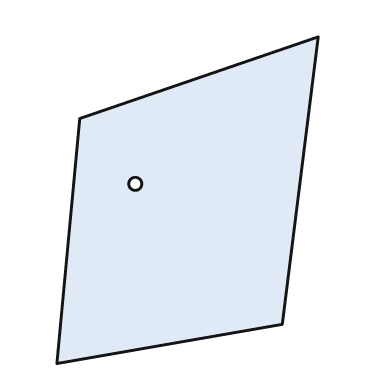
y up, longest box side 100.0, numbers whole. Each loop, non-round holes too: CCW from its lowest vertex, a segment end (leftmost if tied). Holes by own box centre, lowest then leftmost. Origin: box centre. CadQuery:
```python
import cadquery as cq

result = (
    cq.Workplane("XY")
    .moveTo(-40.0, -50.0)
    .lineTo(29.0, -38.0)
    .lineTo(40.0, 50.0)
    .lineTo(-33.0, 25.0)
    .close()
    .moveTo(-16.0, 5.0)
    .circle(2.0)
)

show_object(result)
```